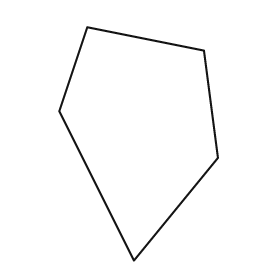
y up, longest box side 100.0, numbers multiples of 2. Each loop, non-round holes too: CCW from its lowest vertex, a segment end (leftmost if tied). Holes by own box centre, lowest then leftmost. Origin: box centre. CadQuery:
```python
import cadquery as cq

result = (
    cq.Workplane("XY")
    .moveTo(-2.0, -50.0)
    .lineTo(34.0, -6.0)
    .lineTo(28.0, 40.0)
    .lineTo(-22.0, 50.0)
    .lineTo(-34.0, 14.0)
    .close()
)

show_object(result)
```